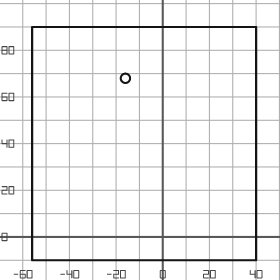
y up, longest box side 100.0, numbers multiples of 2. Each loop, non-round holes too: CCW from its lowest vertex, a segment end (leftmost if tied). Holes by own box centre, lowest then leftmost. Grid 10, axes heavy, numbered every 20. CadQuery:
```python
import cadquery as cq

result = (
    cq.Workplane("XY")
    .moveTo(-56.0, -10.0)
    .lineTo(40.0, -10.0)
    .lineTo(40.0, 90.0)
    .lineTo(-56.0, 90.0)
    .close()
    .moveTo(-16.0, 68.0)
    .circle(2.0)
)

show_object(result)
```